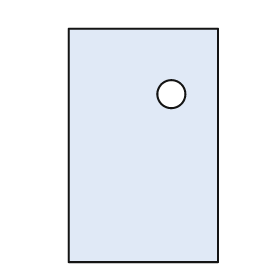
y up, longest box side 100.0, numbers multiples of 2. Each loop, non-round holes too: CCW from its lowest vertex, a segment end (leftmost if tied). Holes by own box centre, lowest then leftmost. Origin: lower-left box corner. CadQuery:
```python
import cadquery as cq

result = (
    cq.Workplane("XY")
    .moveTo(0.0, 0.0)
    .lineTo(64.0, 0.0)
    .lineTo(64.0, 100.0)
    .lineTo(0.0, 100.0)
    .close()
    .moveTo(44.0, 72.0)
    .circle(6.0)
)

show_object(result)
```